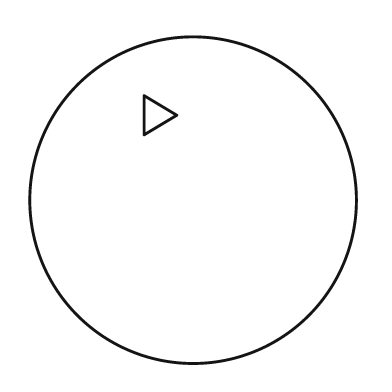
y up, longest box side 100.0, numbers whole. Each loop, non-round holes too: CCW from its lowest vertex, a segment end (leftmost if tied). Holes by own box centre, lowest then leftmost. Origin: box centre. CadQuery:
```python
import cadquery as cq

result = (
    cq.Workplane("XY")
    .moveTo(0.0, 0.0)
    .circle(50.0)
    .moveTo(-15.0, 20.0)
    .lineTo(-5.0, 26.0)
    .lineTo(-15.0, 32.0)
    .close()
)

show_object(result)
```